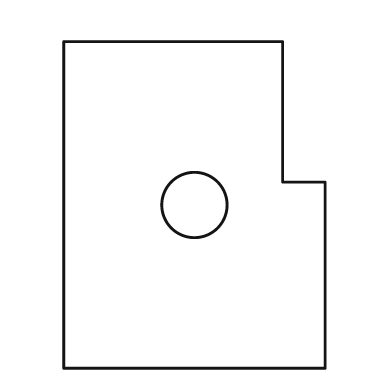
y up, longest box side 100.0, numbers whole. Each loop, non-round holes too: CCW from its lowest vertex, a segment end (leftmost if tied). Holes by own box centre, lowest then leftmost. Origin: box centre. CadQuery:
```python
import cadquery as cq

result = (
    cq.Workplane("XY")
    .moveTo(-40.0, -50.0)
    .lineTo(40.0, -50.0)
    .lineTo(40.0, 7.0)
    .lineTo(27.0, 7.0)
    .lineTo(27.0, 50.0)
    .lineTo(-40.0, 50.0)
    .close()
    .moveTo(0.0, 0.0)
    .circle(10.0)
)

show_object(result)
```